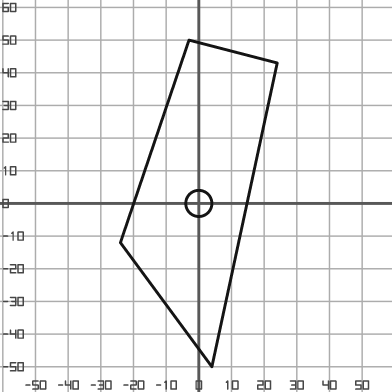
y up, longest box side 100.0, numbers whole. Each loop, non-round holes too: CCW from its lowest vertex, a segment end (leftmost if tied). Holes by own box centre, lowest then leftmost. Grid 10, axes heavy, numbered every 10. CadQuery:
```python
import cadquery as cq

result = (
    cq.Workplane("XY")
    .moveTo(4.0, -50.0)
    .lineTo(24.0, 43.0)
    .lineTo(-3.0, 50.0)
    .lineTo(-24.0, -12.0)
    .close()
    .moveTo(0.0, 0.0)
    .circle(4.0)
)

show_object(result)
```